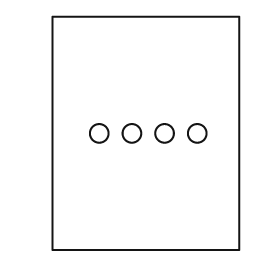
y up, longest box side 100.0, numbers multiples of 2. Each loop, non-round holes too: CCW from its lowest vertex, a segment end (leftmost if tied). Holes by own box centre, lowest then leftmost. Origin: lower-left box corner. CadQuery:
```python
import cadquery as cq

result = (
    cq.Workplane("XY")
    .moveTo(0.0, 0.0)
    .lineTo(80.0, 0.0)
    .lineTo(80.0, 100.0)
    .lineTo(0.0, 100.0)
    .close()
    .moveTo(20.0, 50.0)
    .circle(4.0)
    .moveTo(34.0, 50.0)
    .circle(4.0)
    .moveTo(48.0, 50.0)
    .circle(4.0)
    .moveTo(62.0, 50.0)
    .circle(4.0)
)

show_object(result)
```